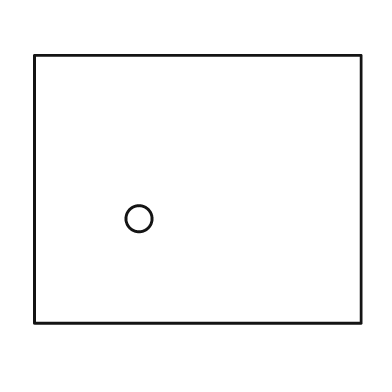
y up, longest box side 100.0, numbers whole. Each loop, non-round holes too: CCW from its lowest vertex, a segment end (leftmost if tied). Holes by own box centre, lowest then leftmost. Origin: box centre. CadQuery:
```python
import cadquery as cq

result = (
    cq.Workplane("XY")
    .moveTo(-50.0, -41.0)
    .lineTo(50.0, -41.0)
    .lineTo(50.0, 41.0)
    .lineTo(-50.0, 41.0)
    .close()
    .moveTo(-18.0, -9.0)
    .circle(4.0)
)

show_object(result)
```